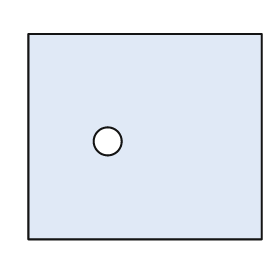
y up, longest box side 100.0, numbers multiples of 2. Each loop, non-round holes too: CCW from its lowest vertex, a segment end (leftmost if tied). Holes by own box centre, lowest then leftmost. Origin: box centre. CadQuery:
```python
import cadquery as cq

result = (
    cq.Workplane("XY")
    .moveTo(-50.0, -44.0)
    .lineTo(50.0, -44.0)
    .lineTo(50.0, 44.0)
    .lineTo(-50.0, 44.0)
    .close()
    .moveTo(-16.0, -2.0)
    .circle(6.0)
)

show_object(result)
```